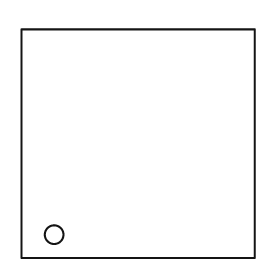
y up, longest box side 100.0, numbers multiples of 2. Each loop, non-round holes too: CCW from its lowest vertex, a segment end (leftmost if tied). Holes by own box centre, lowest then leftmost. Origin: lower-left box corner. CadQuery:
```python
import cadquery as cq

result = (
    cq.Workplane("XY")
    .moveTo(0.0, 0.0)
    .lineTo(100.0, 0.0)
    .lineTo(100.0, 98.0)
    .lineTo(0.0, 98.0)
    .close()
    .moveTo(14.0, 10.0)
    .circle(4.0)
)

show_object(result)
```